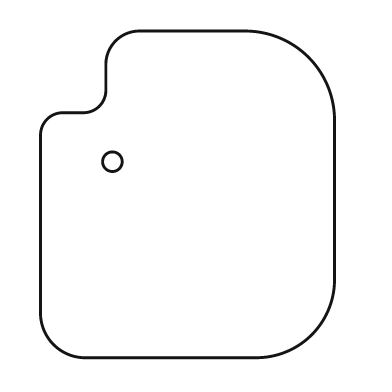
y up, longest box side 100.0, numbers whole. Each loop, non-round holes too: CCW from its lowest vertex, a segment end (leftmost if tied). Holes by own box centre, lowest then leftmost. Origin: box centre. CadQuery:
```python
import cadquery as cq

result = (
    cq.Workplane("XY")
    .moveTo(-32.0, -50.0)
    .lineTo(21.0, -50.0)
    .threePointArc((38.0, -43.0), (45.0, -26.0))
    .lineTo(45.0, 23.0)
    .threePointArc((37.0, 42.0), (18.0, 50.0))
    .lineTo(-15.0, 50.0)
    .threePointArc((-22.0, 47.0), (-25.0, 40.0))
    .lineTo(-25.0, 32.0)
    .threePointArc((-27.0, 27.0), (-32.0, 25.0))
    .lineTo(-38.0, 25.0)
    .threePointArc((-43.0, 23.0), (-45.0, 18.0))
    .lineTo(-45.0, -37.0)
    .threePointArc((-41.0, -46.0), (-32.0, -50.0))
    .close()
    .moveTo(-23.0, 10.0)
    .circle(3.0)
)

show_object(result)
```